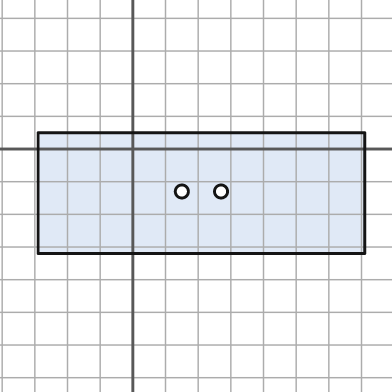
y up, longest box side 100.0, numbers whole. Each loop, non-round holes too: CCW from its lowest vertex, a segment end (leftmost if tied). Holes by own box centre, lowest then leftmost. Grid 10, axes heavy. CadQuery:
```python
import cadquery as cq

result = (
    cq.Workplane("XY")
    .moveTo(-29.0, -32.0)
    .lineTo(71.0, -32.0)
    .lineTo(71.0, 5.0)
    .lineTo(-29.0, 5.0)
    .close()
    .moveTo(15.0, -13.0)
    .circle(2.0)
    .moveTo(27.0, -13.0)
    .circle(2.0)
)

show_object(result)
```